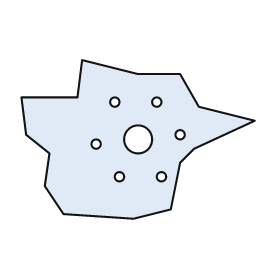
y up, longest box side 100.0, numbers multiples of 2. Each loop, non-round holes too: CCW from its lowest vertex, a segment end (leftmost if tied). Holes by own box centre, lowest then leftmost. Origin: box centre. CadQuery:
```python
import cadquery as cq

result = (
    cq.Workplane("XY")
    .moveTo(-2.0, -34.0)
    .lineTo(14.0, -30.0)
    .lineTo(18.0, -10.0)
    .lineTo(24.0, -4.0)
    .lineTo(50.0, 8.0)
    .lineTo(26.0, 14.0)
    .lineTo(18.0, 28.0)
    .lineTo(0.0, 28.0)
    .lineTo(-24.0, 34.0)
    .lineTo(-26.0, 18.0)
    .lineTo(-50.0, 18.0)
    .lineTo(-48.0, 2.0)
    .lineTo(-38.0, -6.0)
    .lineTo(-40.0, -20.0)
    .lineTo(-32.0, -32.0)
    .close()
    .moveTo(-8.0, -16.0)
    .circle(2.0)
    .moveTo(10.0, -16.0)
    .circle(2.0)
    .moveTo(-18.0, -2.0)
    .circle(2.0)
    .moveTo(0.0, 0.0)
    .circle(6.0)
    .moveTo(18.0, 2.0)
    .circle(2.0)
    .moveTo(-10.0, 16.0)
    .circle(2.0)
    .moveTo(8.0, 16.0)
    .circle(2.0)
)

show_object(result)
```